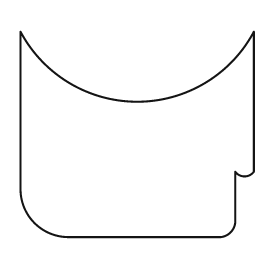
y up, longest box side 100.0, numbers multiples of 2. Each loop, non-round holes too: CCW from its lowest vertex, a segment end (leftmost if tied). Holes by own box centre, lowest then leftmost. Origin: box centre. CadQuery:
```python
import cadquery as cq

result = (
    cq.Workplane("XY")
    .moveTo(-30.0, -44.0)
    .lineTo(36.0, -44.0)
    .threePointArc((40.0, -42.0), (42.0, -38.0))
    .lineTo(42.0, -16.0)
    .threePointArc((46.0, -18.0), (50.0, -16.0))
    .lineTo(50.0, 44.0)
    .threePointArc((0.0, 14.0), (-50.0, 44.0))
    .lineTo(-50.0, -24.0)
    .threePointArc((-44.0, -38.0), (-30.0, -44.0))
    .close()
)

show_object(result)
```